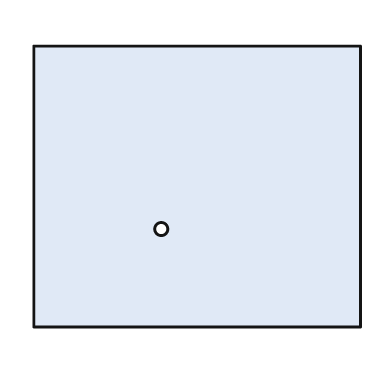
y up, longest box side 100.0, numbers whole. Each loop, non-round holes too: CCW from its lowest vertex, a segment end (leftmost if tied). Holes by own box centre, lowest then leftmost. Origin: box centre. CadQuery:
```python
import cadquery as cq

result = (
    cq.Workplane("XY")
    .moveTo(-50.0, -43.0)
    .lineTo(50.0, -43.0)
    .lineTo(50.0, 43.0)
    .lineTo(-50.0, 43.0)
    .close()
    .moveTo(-11.0, -13.0)
    .circle(2.0)
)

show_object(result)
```